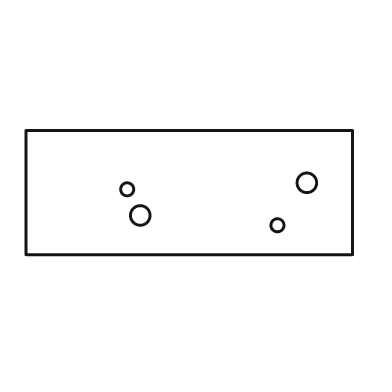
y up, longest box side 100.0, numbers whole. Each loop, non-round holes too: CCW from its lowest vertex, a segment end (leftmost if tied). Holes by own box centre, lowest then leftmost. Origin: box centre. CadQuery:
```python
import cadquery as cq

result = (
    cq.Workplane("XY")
    .moveTo(-50.0, -19.0)
    .lineTo(50.0, -19.0)
    .lineTo(50.0, 19.0)
    .lineTo(-50.0, 19.0)
    .close()
    .moveTo(27.0, -10.0)
    .circle(2.0)
    .moveTo(-15.0, -7.0)
    .circle(3.0)
    .moveTo(-19.0, 1.0)
    .circle(2.0)
    .moveTo(36.0, 3.0)
    .circle(3.0)
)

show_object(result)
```